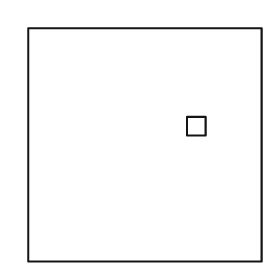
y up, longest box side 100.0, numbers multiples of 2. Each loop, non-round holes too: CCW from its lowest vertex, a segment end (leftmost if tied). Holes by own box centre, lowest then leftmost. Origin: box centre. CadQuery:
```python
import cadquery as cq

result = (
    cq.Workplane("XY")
    .moveTo(-50.0, -50.0)
    .lineTo(50.0, -50.0)
    .lineTo(50.0, 50.0)
    .lineTo(-50.0, 50.0)
    .close()
    .moveTo(18.0, 4.0)
    .lineTo(26.0, 4.0)
    .lineTo(26.0, 12.0)
    .lineTo(18.0, 12.0)
    .close()
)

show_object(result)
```